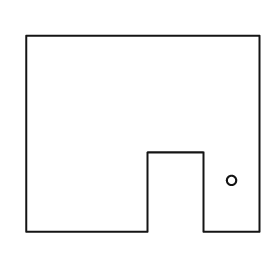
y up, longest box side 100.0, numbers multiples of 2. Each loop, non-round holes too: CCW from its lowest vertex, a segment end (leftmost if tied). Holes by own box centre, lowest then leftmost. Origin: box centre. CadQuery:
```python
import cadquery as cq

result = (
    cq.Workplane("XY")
    .moveTo(-50.0, -42.0)
    .lineTo(2.0, -42.0)
    .lineTo(2.0, -8.0)
    .lineTo(26.0, -8.0)
    .lineTo(26.0, -42.0)
    .lineTo(50.0, -42.0)
    .lineTo(50.0, 42.0)
    .lineTo(-50.0, 42.0)
    .close()
    .moveTo(38.0, -20.0)
    .circle(2.0)
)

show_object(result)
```